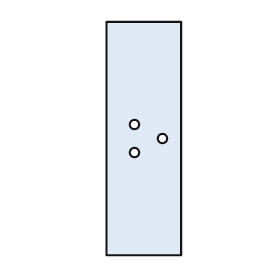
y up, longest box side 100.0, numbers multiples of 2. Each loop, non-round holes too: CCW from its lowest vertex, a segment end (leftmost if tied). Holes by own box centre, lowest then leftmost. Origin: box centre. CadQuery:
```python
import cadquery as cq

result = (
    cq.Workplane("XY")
    .moveTo(-16.0, -50.0)
    .lineTo(16.0, -50.0)
    .lineTo(16.0, 50.0)
    .lineTo(-16.0, 50.0)
    .close()
    .moveTo(-4.0, -6.0)
    .circle(2.0)
    .moveTo(8.0, 0.0)
    .circle(2.0)
    .moveTo(-4.0, 6.0)
    .circle(2.0)
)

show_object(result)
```